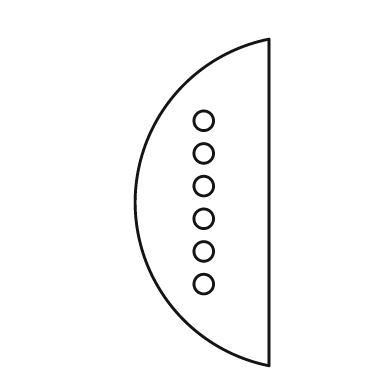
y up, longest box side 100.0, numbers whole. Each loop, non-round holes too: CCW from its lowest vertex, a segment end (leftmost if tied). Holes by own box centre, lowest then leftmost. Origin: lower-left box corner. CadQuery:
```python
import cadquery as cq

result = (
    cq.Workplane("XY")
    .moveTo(41.0, 0.0)
    .lineTo(41.0, 100.0)
    .threePointArc((0.0, 50.0), (41.0, 0.0))
    .close()
    .moveTo(21.0, 25.0)
    .circle(3.0)
    .moveTo(21.0, 35.0)
    .circle(3.0)
    .moveTo(21.0, 45.0)
    .circle(3.0)
    .moveTo(21.0, 55.0)
    .circle(3.0)
    .moveTo(21.0, 65.0)
    .circle(3.0)
    .moveTo(21.0, 75.0)
    .circle(3.0)
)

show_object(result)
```